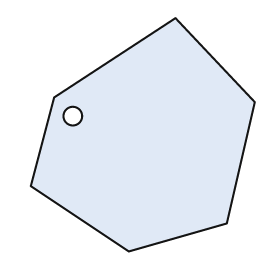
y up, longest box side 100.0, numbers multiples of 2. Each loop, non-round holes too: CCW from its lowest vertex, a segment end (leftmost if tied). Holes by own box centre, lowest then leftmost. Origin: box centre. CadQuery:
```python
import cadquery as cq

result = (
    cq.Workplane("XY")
    .moveTo(-6.0, -50.0)
    .lineTo(36.0, -38.0)
    .lineTo(48.0, 14.0)
    .lineTo(14.0, 50.0)
    .lineTo(-38.0, 16.0)
    .lineTo(-48.0, -22.0)
    .close()
    .moveTo(-30.0, 8.0)
    .circle(4.0)
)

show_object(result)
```